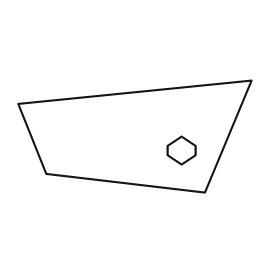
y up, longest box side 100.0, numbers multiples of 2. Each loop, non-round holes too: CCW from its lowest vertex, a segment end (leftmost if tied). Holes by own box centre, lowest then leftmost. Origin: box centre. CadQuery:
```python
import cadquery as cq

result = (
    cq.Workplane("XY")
    .moveTo(30.0, -24.0)
    .lineTo(50.0, 24.0)
    .lineTo(-50.0, 14.0)
    .lineTo(-38.0, -16.0)
    .close()
    .moveTo(20.0, -12.0)
    .lineTo(26.0, -8.0)
    .lineTo(26.0, -4.0)
    .lineTo(20.0, 0.0)
    .lineTo(14.0, -4.0)
    .lineTo(14.0, -8.0)
    .close()
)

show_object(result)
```